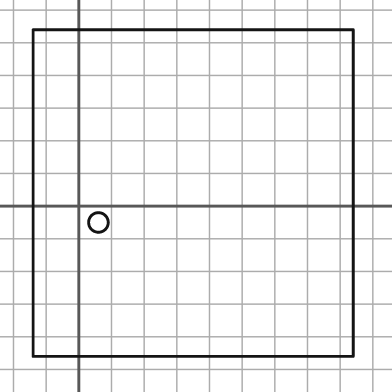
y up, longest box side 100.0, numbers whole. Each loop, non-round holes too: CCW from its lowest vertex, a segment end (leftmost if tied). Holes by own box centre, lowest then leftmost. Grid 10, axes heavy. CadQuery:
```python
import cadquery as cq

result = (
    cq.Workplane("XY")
    .moveTo(-14.0, -46.0)
    .lineTo(84.0, -46.0)
    .lineTo(84.0, 54.0)
    .lineTo(-14.0, 54.0)
    .close()
    .moveTo(6.0, -5.0)
    .circle(3.0)
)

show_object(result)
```